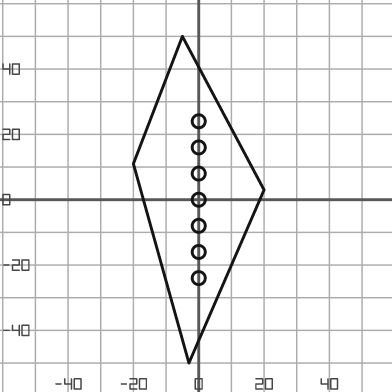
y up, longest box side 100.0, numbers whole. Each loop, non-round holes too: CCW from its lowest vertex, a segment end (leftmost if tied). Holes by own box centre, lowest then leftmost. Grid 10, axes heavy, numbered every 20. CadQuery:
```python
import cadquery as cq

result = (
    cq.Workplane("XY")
    .moveTo(-3.0, -50.0)
    .lineTo(20.0, 3.0)
    .lineTo(-5.0, 50.0)
    .lineTo(-20.0, 11.0)
    .close()
    .moveTo(0.0, -24.0)
    .circle(2.0)
    .moveTo(0.0, -16.0)
    .circle(2.0)
    .moveTo(0.0, -8.0)
    .circle(2.0)
    .moveTo(0.0, 0.0)
    .circle(2.0)
    .moveTo(0.0, 8.0)
    .circle(2.0)
    .moveTo(0.0, 16.0)
    .circle(2.0)
    .moveTo(0.0, 24.0)
    .circle(2.0)
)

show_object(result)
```